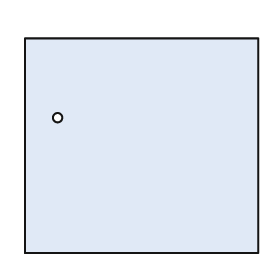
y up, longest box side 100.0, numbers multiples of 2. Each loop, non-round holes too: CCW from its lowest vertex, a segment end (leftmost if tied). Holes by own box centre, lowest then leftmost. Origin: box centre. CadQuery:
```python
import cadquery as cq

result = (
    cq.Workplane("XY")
    .moveTo(-50.0, -46.0)
    .lineTo(50.0, -46.0)
    .lineTo(50.0, 46.0)
    .lineTo(-50.0, 46.0)
    .close()
    .moveTo(-36.0, 12.0)
    .circle(2.0)
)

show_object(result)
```